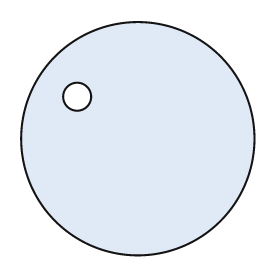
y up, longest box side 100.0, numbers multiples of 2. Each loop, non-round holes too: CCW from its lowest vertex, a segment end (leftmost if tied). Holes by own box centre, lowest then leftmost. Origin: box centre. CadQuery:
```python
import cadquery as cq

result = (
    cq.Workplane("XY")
    .moveTo(0.0, 0.0)
    .circle(50.0)
    .moveTo(-26.0, 18.0)
    .circle(6.0)
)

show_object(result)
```